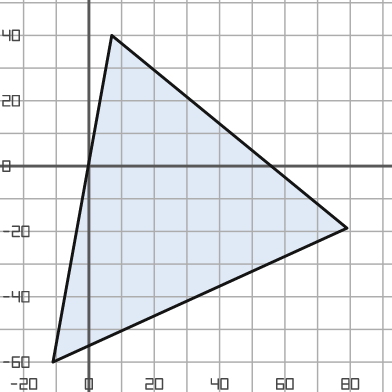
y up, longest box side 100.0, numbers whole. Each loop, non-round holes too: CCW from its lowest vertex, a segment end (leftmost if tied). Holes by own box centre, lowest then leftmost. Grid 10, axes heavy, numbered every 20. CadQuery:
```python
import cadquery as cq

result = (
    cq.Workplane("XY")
    .moveTo(-11.0, -60.0)
    .lineTo(79.0, -19.0)
    .lineTo(7.0, 40.0)
    .close()
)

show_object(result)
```